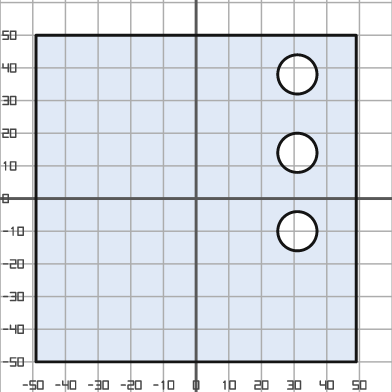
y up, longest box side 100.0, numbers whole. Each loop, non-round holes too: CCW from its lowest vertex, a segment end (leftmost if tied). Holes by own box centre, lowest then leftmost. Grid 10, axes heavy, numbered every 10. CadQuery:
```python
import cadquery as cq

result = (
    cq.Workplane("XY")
    .moveTo(-49.0, -50.0)
    .lineTo(49.0, -50.0)
    .lineTo(49.0, 50.0)
    .lineTo(-49.0, 50.0)
    .close()
    .moveTo(31.0, -10.0)
    .circle(6.0)
    .moveTo(31.0, 14.0)
    .circle(6.0)
    .moveTo(31.0, 38.0)
    .circle(6.0)
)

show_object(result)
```